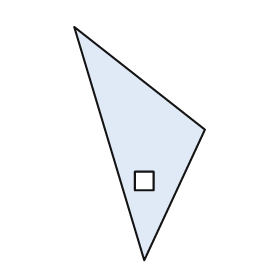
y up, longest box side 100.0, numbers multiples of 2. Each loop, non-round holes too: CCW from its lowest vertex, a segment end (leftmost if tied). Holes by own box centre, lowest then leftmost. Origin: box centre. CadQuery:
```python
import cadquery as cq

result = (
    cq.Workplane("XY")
    .moveTo(2.0, -50.0)
    .lineTo(28.0, 6.0)
    .lineTo(-28.0, 50.0)
    .close()
    .moveTo(-2.0, -20.0)
    .lineTo(6.0, -20.0)
    .lineTo(6.0, -12.0)
    .lineTo(-2.0, -12.0)
    .close()
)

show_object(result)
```